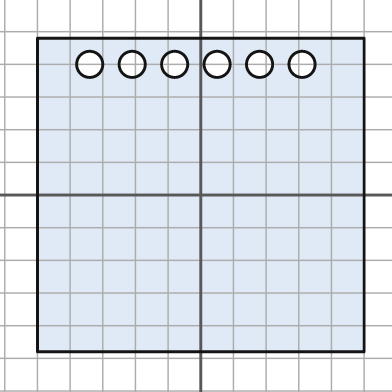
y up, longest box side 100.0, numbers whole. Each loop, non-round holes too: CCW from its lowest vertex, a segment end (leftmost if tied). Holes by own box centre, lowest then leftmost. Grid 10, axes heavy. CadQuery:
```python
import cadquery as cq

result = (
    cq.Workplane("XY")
    .moveTo(-50.0, -48.0)
    .lineTo(50.0, -48.0)
    .lineTo(50.0, 48.0)
    .lineTo(-50.0, 48.0)
    .close()
    .moveTo(-34.0, 40.0)
    .circle(4.0)
    .moveTo(-21.0, 40.0)
    .circle(4.0)
    .moveTo(-8.0, 40.0)
    .circle(4.0)
    .moveTo(5.0, 40.0)
    .circle(4.0)
    .moveTo(18.0, 40.0)
    .circle(4.0)
    .moveTo(31.0, 40.0)
    .circle(4.0)
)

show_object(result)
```